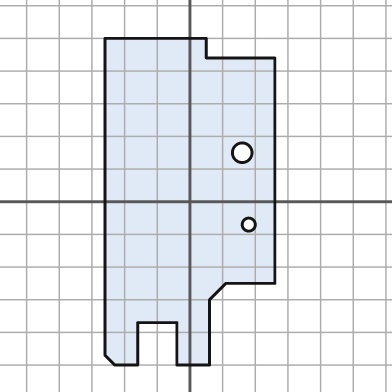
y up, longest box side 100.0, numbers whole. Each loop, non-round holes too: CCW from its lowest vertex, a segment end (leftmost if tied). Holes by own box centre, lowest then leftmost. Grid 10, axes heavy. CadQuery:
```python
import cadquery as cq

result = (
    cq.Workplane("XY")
    .moveTo(-23.0, -50.0)
    .lineTo(-16.0, -50.0)
    .lineTo(-16.0, -37.0)
    .lineTo(-4.0, -37.0)
    .lineTo(-4.0, -50.0)
    .lineTo(6.0, -50.0)
    .lineTo(6.0, -30.0)
    .lineTo(11.0, -25.0)
    .lineTo(26.0, -25.0)
    .lineTo(26.0, 44.0)
    .lineTo(5.0, 44.0)
    .lineTo(5.0, 50.0)
    .lineTo(-26.0, 50.0)
    .lineTo(-26.0, -47.0)
    .close()
    .moveTo(18.0, -7.0)
    .circle(2.0)
    .moveTo(16.0, 15.0)
    .circle(3.0)
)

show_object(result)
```